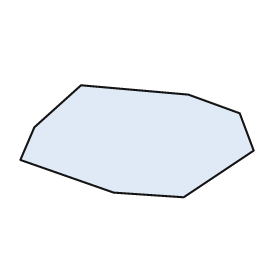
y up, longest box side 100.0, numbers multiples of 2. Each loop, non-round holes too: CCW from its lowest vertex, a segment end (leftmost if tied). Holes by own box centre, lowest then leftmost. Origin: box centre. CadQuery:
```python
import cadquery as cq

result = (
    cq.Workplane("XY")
    .moveTo(20.0, -24.0)
    .lineTo(50.0, -4.0)
    .lineTo(44.0, 12.0)
    .lineTo(22.0, 20.0)
    .lineTo(-24.0, 24.0)
    .lineTo(-44.0, 6.0)
    .lineTo(-50.0, -8.0)
    .lineTo(-10.0, -22.0)
    .close()
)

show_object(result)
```